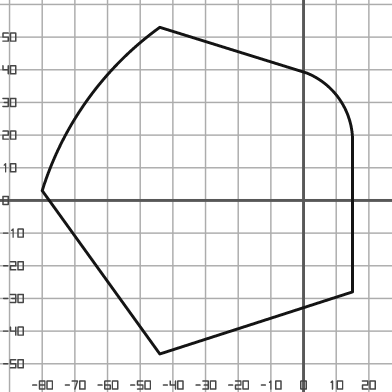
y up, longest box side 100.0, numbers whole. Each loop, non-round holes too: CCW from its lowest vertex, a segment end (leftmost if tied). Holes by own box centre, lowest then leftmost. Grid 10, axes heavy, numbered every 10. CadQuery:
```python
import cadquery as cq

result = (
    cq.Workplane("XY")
    .moveTo(-44.0, -47.0)
    .lineTo(15.0, -28.0)
    .lineTo(15.0, 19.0)
    .threePointArc((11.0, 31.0), (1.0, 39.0))
    .lineTo(-44.0, 53.0)
    .threePointArc((-66.0, 31.0), (-80.0, 3.0))
    .close()
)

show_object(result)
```